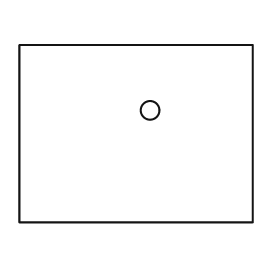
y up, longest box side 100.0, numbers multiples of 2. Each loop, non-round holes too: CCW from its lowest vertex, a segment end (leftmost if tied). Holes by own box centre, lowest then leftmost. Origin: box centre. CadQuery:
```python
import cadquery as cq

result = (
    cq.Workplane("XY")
    .moveTo(-50.0, -38.0)
    .lineTo(50.0, -38.0)
    .lineTo(50.0, 38.0)
    .lineTo(-50.0, 38.0)
    .close()
    .moveTo(6.0, 10.0)
    .circle(4.0)
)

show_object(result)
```